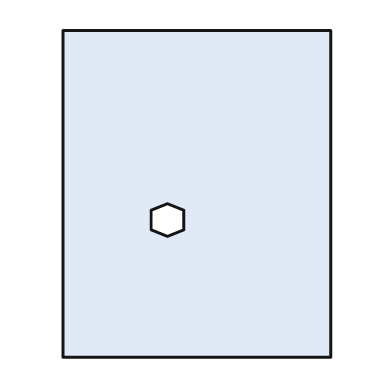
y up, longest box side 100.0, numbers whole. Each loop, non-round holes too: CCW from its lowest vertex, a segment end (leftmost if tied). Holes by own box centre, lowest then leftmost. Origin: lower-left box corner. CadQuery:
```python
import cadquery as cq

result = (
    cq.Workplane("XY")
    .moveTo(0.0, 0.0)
    .lineTo(82.0, 0.0)
    .lineTo(82.0, 100.0)
    .lineTo(0.0, 100.0)
    .close()
    .moveTo(32.0, 37.0)
    .lineTo(37.0, 39.0)
    .lineTo(37.0, 45.0)
    .lineTo(32.0, 47.0)
    .lineTo(27.0, 45.0)
    .lineTo(27.0, 39.0)
    .close()
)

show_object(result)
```